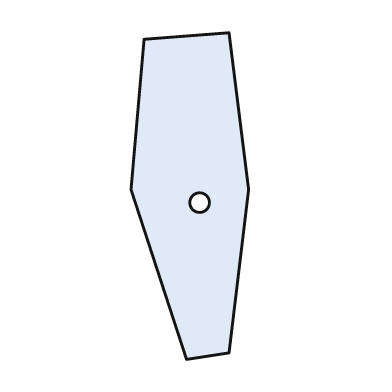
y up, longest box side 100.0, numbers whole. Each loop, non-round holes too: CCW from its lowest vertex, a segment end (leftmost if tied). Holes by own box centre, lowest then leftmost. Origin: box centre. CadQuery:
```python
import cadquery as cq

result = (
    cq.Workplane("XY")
    .moveTo(-1.0, -50.0)
    .lineTo(12.0, -48.0)
    .lineTo(18.0, 2.0)
    .lineTo(12.0, 50.0)
    .lineTo(-14.0, 48.0)
    .lineTo(-18.0, 2.0)
    .close()
    .moveTo(3.0, -2.0)
    .circle(3.0)
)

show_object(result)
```